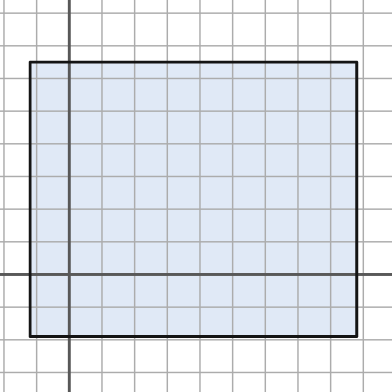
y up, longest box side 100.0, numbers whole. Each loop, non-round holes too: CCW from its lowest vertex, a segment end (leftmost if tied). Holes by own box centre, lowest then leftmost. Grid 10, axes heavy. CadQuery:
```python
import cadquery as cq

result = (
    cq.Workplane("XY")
    .moveTo(-12.0, -19.0)
    .lineTo(88.0, -19.0)
    .lineTo(88.0, 65.0)
    .lineTo(-12.0, 65.0)
    .close()
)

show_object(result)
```